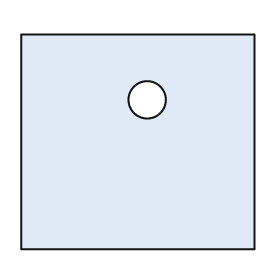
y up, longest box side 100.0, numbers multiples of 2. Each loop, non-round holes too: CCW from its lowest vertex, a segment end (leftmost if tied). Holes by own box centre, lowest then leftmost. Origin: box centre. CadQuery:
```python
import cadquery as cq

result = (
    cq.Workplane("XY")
    .moveTo(-50.0, -46.0)
    .lineTo(50.0, -46.0)
    .lineTo(50.0, 46.0)
    .lineTo(-50.0, 46.0)
    .close()
    .moveTo(4.0, 18.0)
    .circle(8.0)
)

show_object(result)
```